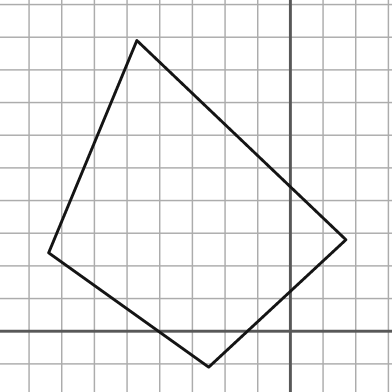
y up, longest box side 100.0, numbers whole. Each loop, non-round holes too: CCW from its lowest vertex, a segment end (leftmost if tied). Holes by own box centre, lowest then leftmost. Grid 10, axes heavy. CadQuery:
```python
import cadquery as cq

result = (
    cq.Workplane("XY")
    .moveTo(-25.0, -11.0)
    .lineTo(17.0, 28.0)
    .lineTo(-47.0, 89.0)
    .lineTo(-74.0, 24.0)
    .close()
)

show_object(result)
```